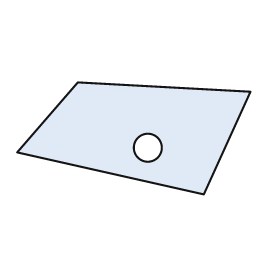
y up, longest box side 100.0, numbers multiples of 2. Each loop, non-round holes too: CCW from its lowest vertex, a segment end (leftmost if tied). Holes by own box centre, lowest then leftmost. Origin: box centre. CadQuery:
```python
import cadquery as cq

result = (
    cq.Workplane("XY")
    .moveTo(30.0, -24.0)
    .lineTo(50.0, 20.0)
    .lineTo(-24.0, 24.0)
    .lineTo(-50.0, -6.0)
    .close()
    .moveTo(6.0, -4.0)
    .circle(6.0)
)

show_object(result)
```